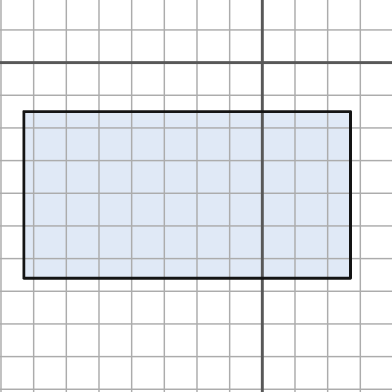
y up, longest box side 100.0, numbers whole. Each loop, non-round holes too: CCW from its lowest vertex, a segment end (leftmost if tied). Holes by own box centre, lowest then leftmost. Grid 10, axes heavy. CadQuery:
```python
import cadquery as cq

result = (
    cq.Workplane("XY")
    .moveTo(-73.0, -66.0)
    .lineTo(27.0, -66.0)
    .lineTo(27.0, -15.0)
    .lineTo(-73.0, -15.0)
    .close()
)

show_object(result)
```